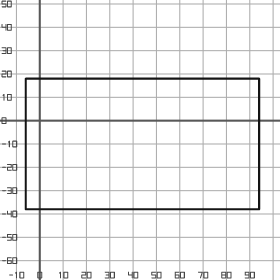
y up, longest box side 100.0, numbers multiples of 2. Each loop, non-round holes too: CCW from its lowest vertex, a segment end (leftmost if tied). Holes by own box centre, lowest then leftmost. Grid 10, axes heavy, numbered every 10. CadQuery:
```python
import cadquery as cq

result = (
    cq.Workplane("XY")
    .moveTo(-6.0, -38.0)
    .lineTo(94.0, -38.0)
    .lineTo(94.0, 18.0)
    .lineTo(-6.0, 18.0)
    .close()
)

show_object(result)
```